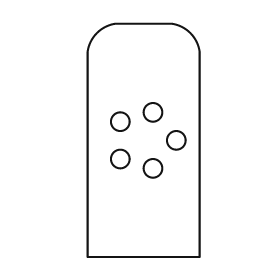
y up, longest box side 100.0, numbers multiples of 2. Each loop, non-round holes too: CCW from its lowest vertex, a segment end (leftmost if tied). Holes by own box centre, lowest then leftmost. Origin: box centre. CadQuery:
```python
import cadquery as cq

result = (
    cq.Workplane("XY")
    .moveTo(-24.0, -50.0)
    .lineTo(24.0, -50.0)
    .lineTo(24.0, 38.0)
    .threePointArc((20.0, 46.0), (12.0, 50.0))
    .lineTo(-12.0, 50.0)
    .threePointArc((-20.0, 46.0), (-24.0, 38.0))
    .close()
    .moveTo(4.0, -12.0)
    .circle(4.0)
    .moveTo(-10.0, -8.0)
    .circle(4.0)
    .moveTo(14.0, 0.0)
    .circle(4.0)
    .moveTo(-10.0, 8.0)
    .circle(4.0)
    .moveTo(4.0, 12.0)
    .circle(4.0)
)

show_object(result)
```